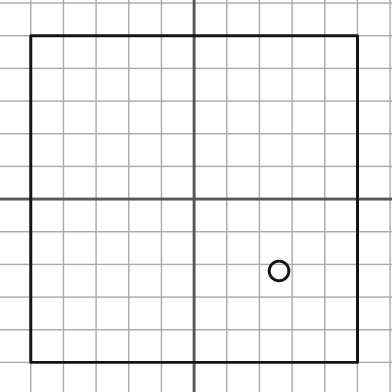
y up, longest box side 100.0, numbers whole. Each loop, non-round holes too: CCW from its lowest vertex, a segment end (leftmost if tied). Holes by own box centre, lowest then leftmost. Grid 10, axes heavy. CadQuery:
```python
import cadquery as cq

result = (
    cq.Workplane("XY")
    .moveTo(-50.0, -50.0)
    .lineTo(50.0, -50.0)
    .lineTo(50.0, 50.0)
    .lineTo(-50.0, 50.0)
    .close()
    .moveTo(26.0, -22.0)
    .circle(3.0)
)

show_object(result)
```